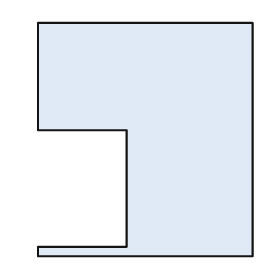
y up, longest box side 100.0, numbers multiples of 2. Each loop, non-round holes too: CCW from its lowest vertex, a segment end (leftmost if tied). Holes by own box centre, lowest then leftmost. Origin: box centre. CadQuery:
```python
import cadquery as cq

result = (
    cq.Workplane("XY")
    .moveTo(-46.0, -50.0)
    .lineTo(46.0, -50.0)
    .lineTo(46.0, 50.0)
    .lineTo(-46.0, 50.0)
    .lineTo(-46.0, 4.0)
    .lineTo(-8.0, 4.0)
    .lineTo(-8.0, -46.0)
    .lineTo(-46.0, -46.0)
    .close()
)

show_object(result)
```